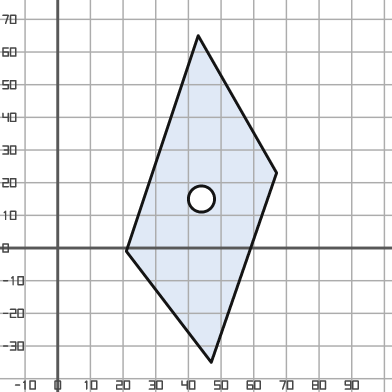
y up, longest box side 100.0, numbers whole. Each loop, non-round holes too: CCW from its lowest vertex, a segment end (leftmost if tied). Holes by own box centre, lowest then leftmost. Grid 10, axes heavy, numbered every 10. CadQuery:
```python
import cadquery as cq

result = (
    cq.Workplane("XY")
    .moveTo(47.0, -35.0)
    .lineTo(67.0, 23.0)
    .lineTo(43.0, 65.0)
    .lineTo(21.0, -1.0)
    .close()
    .moveTo(44.0, 15.0)
    .circle(4.0)
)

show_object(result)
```